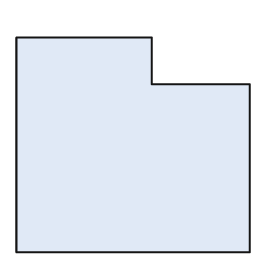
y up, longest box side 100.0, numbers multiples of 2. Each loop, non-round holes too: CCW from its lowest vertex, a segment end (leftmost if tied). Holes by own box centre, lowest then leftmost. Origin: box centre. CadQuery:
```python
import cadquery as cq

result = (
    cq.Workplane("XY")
    .moveTo(-50.0, -46.0)
    .lineTo(50.0, -46.0)
    .lineTo(50.0, 26.0)
    .lineTo(8.0, 26.0)
    .lineTo(8.0, 46.0)
    .lineTo(-50.0, 46.0)
    .close()
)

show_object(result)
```